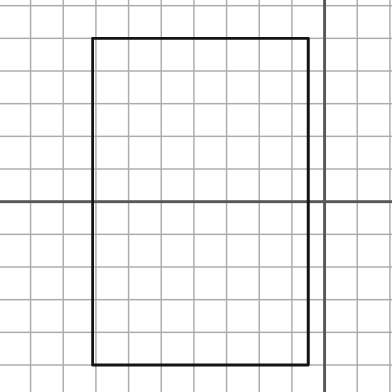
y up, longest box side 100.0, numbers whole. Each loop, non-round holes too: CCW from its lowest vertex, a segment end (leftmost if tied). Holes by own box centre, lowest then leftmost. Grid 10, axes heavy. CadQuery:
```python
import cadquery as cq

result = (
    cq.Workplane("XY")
    .moveTo(-71.0, -50.0)
    .lineTo(-5.0, -50.0)
    .lineTo(-5.0, 50.0)
    .lineTo(-71.0, 50.0)
    .close()
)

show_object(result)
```